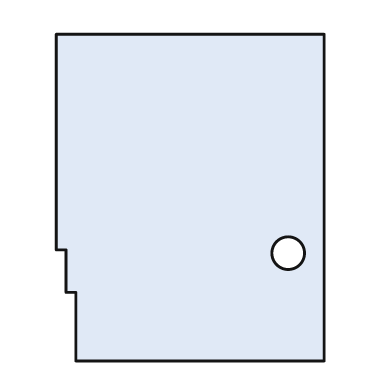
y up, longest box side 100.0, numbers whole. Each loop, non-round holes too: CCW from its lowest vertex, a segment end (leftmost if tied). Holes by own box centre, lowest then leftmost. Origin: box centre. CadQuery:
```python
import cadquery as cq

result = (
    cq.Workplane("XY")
    .moveTo(-35.0, -50.0)
    .lineTo(41.0, -50.0)
    .lineTo(41.0, 50.0)
    .lineTo(-41.0, 50.0)
    .lineTo(-41.0, -16.0)
    .lineTo(-38.0, -16.0)
    .lineTo(-38.0, -29.0)
    .lineTo(-35.0, -29.0)
    .close()
    .moveTo(30.0, -17.0)
    .circle(5.0)
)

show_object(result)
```